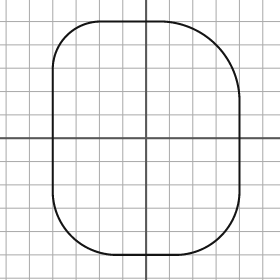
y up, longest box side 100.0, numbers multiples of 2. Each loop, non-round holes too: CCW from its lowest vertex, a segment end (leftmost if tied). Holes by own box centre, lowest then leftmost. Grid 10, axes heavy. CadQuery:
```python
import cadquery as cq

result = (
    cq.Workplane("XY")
    .moveTo(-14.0, -50.0)
    .lineTo(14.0, -50.0)
    .threePointArc((32.0, -42.0), (40.0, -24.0))
    .lineTo(40.0, 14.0)
    .threePointArc((30.0, 40.0), (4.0, 50.0))
    .lineTo(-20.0, 50.0)
    .threePointArc((-34.0, 44.0), (-40.0, 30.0))
    .lineTo(-40.0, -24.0)
    .threePointArc((-32.0, -42.0), (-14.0, -50.0))
    .close()
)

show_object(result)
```